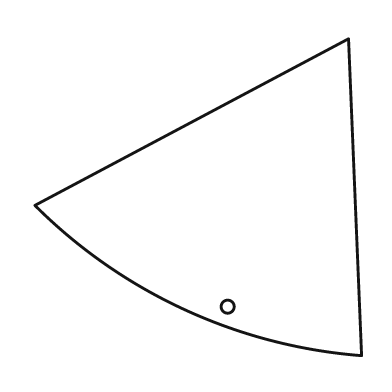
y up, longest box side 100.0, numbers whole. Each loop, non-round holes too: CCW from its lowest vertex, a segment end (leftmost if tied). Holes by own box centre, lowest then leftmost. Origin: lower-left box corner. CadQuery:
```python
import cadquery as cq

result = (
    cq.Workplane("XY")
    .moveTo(100.0, 0.0)
    .lineTo(96.0, 97.0)
    .lineTo(0.0, 46.0)
    .threePointArc((46.0, 14.0), (100.0, 0.0))
    .close()
    .moveTo(59.0, 15.0)
    .circle(2.0)
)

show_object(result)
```